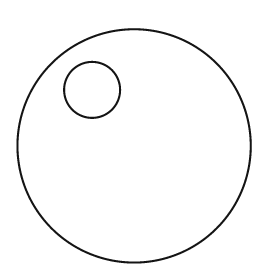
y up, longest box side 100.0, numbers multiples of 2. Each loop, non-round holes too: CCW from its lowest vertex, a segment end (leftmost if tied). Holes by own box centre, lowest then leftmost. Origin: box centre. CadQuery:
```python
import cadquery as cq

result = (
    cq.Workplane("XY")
    .moveTo(0.0, 0.0)
    .circle(50.0)
    .moveTo(-18.0, 24.0)
    .circle(12.0)
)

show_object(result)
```